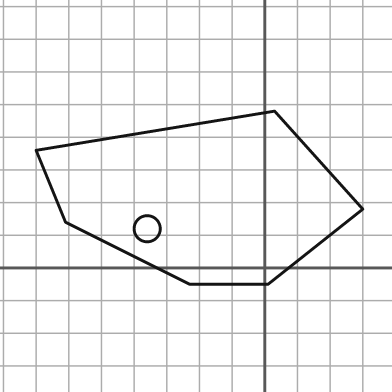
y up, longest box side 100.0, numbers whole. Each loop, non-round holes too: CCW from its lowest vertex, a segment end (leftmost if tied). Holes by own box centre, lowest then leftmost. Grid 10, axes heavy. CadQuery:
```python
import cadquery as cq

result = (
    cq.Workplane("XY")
    .moveTo(-23.0, -5.0)
    .lineTo(1.0, -5.0)
    .lineTo(30.0, 18.0)
    .lineTo(3.0, 48.0)
    .lineTo(-70.0, 36.0)
    .lineTo(-61.0, 14.0)
    .close()
    .moveTo(-36.0, 12.0)
    .circle(4.0)
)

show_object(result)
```